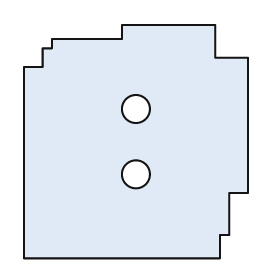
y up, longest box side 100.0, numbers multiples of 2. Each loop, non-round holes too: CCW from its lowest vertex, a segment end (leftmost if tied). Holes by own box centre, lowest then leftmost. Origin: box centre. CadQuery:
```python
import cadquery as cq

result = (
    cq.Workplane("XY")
    .moveTo(-48.0, -50.0)
    .lineTo(36.0, -50.0)
    .lineTo(36.0, -40.0)
    .lineTo(40.0, -40.0)
    .lineTo(40.0, -22.0)
    .lineTo(48.0, -22.0)
    .lineTo(48.0, 36.0)
    .lineTo(34.0, 36.0)
    .lineTo(34.0, 50.0)
    .lineTo(-6.0, 50.0)
    .lineTo(-6.0, 44.0)
    .lineTo(-36.0, 44.0)
    .lineTo(-36.0, 40.0)
    .lineTo(-40.0, 40.0)
    .lineTo(-40.0, 32.0)
    .lineTo(-48.0, 32.0)
    .close()
    .moveTo(0.0, -14.0)
    .circle(6.0)
    .moveTo(0.0, 14.0)
    .circle(6.0)
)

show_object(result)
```